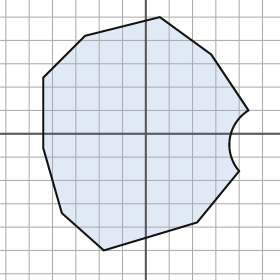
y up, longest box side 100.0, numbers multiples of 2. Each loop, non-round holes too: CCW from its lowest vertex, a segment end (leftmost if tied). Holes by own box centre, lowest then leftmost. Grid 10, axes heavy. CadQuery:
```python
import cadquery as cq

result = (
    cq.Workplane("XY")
    .moveTo(-18.0, -50.0)
    .lineTo(22.0, -38.0)
    .lineTo(40.0, -16.0)
    .threePointArc((36.0, -2.0), (44.0, 10.0))
    .lineTo(28.0, 34.0)
    .lineTo(6.0, 50.0)
    .lineTo(-26.0, 42.0)
    .lineTo(-44.0, 24.0)
    .lineTo(-44.0, -6.0)
    .lineTo(-36.0, -34.0)
    .close()
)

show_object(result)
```